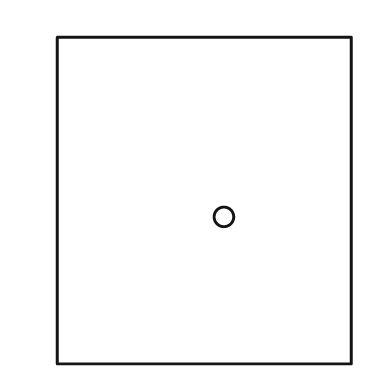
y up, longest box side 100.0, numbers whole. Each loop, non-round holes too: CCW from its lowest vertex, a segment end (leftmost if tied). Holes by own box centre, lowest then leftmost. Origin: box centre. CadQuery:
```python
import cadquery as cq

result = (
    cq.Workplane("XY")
    .moveTo(-45.0, -50.0)
    .lineTo(45.0, -50.0)
    .lineTo(45.0, 50.0)
    .lineTo(-45.0, 50.0)
    .close()
    .moveTo(6.0, -5.0)
    .circle(3.0)
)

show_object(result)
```